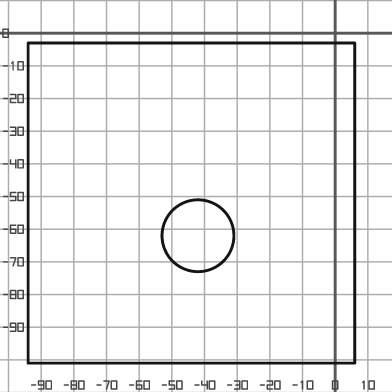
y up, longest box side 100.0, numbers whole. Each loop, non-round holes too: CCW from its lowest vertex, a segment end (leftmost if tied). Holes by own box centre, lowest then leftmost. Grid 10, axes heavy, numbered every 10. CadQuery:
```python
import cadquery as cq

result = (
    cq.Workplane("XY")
    .moveTo(-94.0, -101.0)
    .lineTo(6.0, -101.0)
    .lineTo(6.0, -3.0)
    .lineTo(-94.0, -3.0)
    .close()
    .moveTo(-42.0, -62.0)
    .circle(11.0)
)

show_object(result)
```